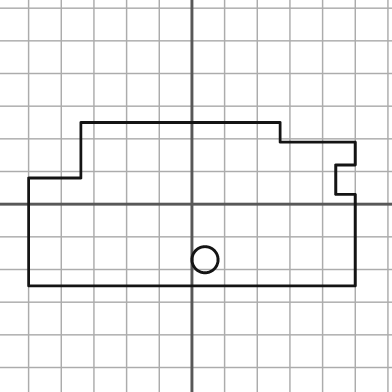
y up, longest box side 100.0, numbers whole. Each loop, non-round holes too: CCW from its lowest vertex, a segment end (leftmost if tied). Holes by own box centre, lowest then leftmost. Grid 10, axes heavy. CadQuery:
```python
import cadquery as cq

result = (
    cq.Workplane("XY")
    .moveTo(-50.0, -25.0)
    .lineTo(50.0, -25.0)
    .lineTo(50.0, 3.0)
    .lineTo(44.0, 3.0)
    .lineTo(44.0, 12.0)
    .lineTo(50.0, 12.0)
    .lineTo(50.0, 19.0)
    .lineTo(27.0, 19.0)
    .lineTo(27.0, 25.0)
    .lineTo(-34.0, 25.0)
    .lineTo(-34.0, 8.0)
    .lineTo(-50.0, 8.0)
    .close()
    .moveTo(4.0, -17.0)
    .circle(4.0)
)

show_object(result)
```